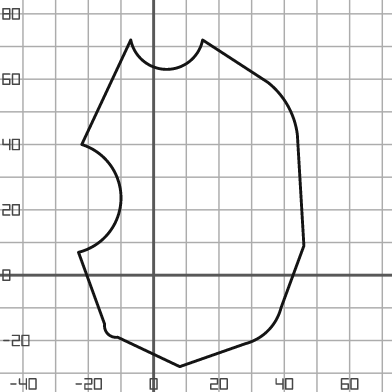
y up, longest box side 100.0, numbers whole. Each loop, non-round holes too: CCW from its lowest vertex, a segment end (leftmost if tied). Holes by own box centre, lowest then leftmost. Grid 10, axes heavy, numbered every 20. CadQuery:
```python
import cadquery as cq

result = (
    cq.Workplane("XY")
    .moveTo(8.0, -28.0)
    .lineTo(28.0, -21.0)
    .threePointArc((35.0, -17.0), (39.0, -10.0))
    .lineTo(46.0, 9.0)
    .lineTo(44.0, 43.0)
    .threePointArc((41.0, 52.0), (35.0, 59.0))
    .lineTo(15.0, 72.0)
    .threePointArc((4.0, 63.0), (-7.0, 72.0))
    .lineTo(-22.0, 40.0)
    .threePointArc((-10.0, 23.0), (-23.0, 7.0))
    .lineTo(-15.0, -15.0)
    .threePointArc((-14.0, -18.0), (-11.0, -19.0))
    .close()
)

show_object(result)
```